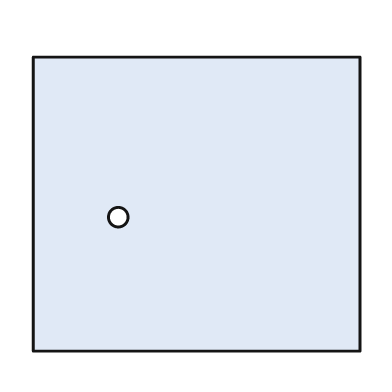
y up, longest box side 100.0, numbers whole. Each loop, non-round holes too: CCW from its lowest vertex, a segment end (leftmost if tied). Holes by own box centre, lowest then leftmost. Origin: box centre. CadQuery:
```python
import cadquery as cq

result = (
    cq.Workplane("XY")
    .moveTo(-50.0, -45.0)
    .lineTo(50.0, -45.0)
    .lineTo(50.0, 45.0)
    .lineTo(-50.0, 45.0)
    .close()
    .moveTo(-24.0, -4.0)
    .circle(3.0)
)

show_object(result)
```